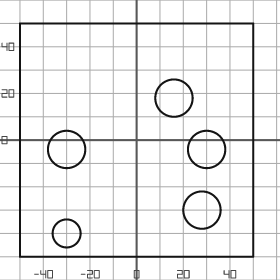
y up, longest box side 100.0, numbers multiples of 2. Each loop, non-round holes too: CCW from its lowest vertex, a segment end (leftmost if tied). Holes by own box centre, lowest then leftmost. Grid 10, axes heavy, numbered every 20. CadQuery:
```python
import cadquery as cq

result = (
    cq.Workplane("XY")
    .moveTo(-50.0, -50.0)
    .lineTo(50.0, -50.0)
    .lineTo(50.0, 50.0)
    .lineTo(-50.0, 50.0)
    .close()
    .moveTo(-30.0, -40.0)
    .circle(6.0)
    .moveTo(28.0, -30.0)
    .circle(8.0)
    .moveTo(-30.0, -4.0)
    .circle(8.0)
    .moveTo(30.0, -4.0)
    .circle(8.0)
    .moveTo(16.0, 18.0)
    .circle(8.0)
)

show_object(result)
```